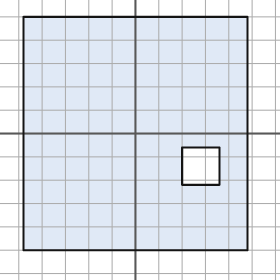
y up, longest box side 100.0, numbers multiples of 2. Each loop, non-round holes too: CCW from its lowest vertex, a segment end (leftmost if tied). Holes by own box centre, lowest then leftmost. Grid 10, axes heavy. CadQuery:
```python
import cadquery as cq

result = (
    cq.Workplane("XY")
    .moveTo(-48.0, -50.0)
    .lineTo(48.0, -50.0)
    .lineTo(48.0, 50.0)
    .lineTo(-48.0, 50.0)
    .close()
    .moveTo(20.0, -22.0)
    .lineTo(36.0, -22.0)
    .lineTo(36.0, -6.0)
    .lineTo(20.0, -6.0)
    .close()
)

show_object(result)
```